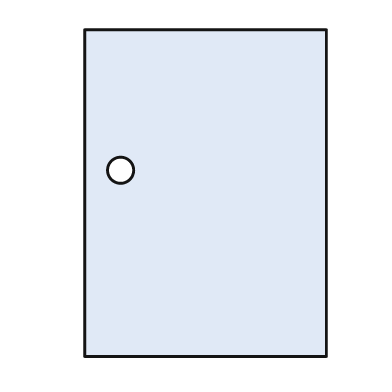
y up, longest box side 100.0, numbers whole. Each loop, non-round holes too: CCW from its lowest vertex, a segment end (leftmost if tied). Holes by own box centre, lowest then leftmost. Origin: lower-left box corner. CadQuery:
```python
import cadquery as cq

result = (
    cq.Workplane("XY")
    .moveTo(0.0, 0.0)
    .lineTo(74.0, 0.0)
    .lineTo(74.0, 100.0)
    .lineTo(0.0, 100.0)
    .close()
    .moveTo(11.0, 57.0)
    .circle(4.0)
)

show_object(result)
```